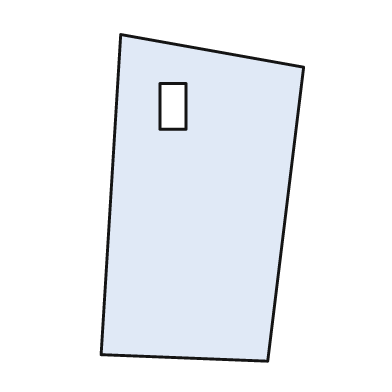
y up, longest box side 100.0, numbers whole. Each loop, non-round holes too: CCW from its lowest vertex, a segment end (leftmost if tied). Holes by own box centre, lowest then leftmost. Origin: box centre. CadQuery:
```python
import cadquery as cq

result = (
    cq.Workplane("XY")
    .moveTo(20.0, -50.0)
    .lineTo(31.0, 40.0)
    .lineTo(-25.0, 50.0)
    .lineTo(-31.0, -48.0)
    .close()
    .moveTo(-13.0, 21.0)
    .lineTo(-5.0, 21.0)
    .lineTo(-5.0, 35.0)
    .lineTo(-13.0, 35.0)
    .close()
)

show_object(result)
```